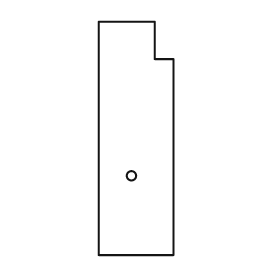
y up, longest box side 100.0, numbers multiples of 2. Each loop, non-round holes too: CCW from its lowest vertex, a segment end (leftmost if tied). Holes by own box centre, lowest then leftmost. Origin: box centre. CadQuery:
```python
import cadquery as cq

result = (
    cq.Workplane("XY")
    .moveTo(-16.0, -50.0)
    .lineTo(16.0, -50.0)
    .lineTo(16.0, 34.0)
    .lineTo(8.0, 34.0)
    .lineTo(8.0, 50.0)
    .lineTo(-16.0, 50.0)
    .close()
    .moveTo(-2.0, -16.0)
    .circle(2.0)
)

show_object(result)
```